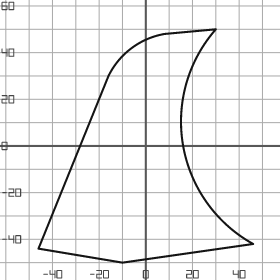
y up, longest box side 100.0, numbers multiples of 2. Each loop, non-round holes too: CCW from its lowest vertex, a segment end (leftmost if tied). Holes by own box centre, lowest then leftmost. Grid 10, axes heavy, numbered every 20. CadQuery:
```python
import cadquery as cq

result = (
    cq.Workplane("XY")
    .moveTo(-10.0, -50.0)
    .lineTo(46.0, -42.0)
    .threePointArc((16.0, 0.0), (30.0, 50.0))
    .lineTo(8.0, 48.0)
    .threePointArc((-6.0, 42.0), (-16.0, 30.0))
    .lineTo(-46.0, -44.0)
    .close()
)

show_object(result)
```